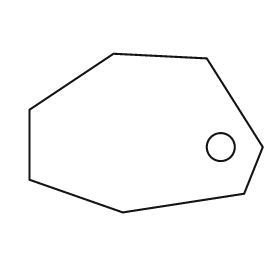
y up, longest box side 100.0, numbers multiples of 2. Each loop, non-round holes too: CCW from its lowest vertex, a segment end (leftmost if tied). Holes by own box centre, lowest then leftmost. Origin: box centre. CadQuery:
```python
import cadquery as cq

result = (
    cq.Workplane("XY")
    .moveTo(-10.0, -34.0)
    .lineTo(42.0, -26.0)
    .lineTo(50.0, -6.0)
    .lineTo(26.0, 32.0)
    .lineTo(-14.0, 34.0)
    .lineTo(-50.0, 10.0)
    .lineTo(-50.0, -20.0)
    .close()
    .moveTo(32.0, -6.0)
    .circle(6.0)
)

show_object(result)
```